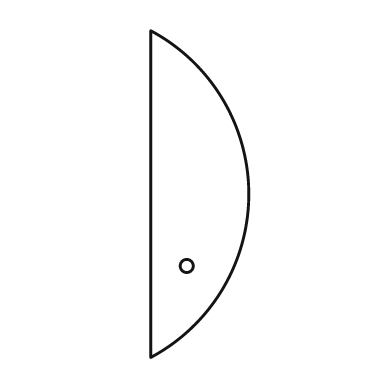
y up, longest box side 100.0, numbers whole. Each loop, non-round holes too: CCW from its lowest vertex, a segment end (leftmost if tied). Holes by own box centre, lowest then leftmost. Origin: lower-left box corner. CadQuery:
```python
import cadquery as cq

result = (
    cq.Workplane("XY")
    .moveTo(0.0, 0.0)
    .threePointArc((30.0, 50.0), (0.0, 100.0))
    .close()
    .moveTo(11.0, 28.0)
    .circle(2.0)
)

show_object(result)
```